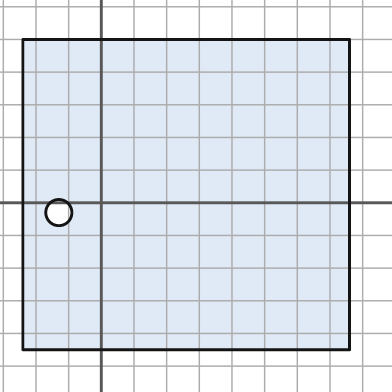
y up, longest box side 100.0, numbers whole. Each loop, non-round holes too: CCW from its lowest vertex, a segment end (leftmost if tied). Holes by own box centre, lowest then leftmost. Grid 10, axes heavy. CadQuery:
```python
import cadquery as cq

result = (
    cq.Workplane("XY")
    .moveTo(-24.0, -45.0)
    .lineTo(76.0, -45.0)
    .lineTo(76.0, 50.0)
    .lineTo(-24.0, 50.0)
    .close()
    .moveTo(-13.0, -3.0)
    .circle(4.0)
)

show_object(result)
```